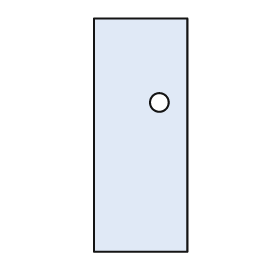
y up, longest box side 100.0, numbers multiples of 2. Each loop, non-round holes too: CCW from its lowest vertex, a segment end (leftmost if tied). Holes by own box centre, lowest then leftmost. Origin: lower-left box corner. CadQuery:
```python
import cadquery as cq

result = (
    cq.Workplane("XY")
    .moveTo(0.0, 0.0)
    .lineTo(40.0, 0.0)
    .lineTo(40.0, 100.0)
    .lineTo(0.0, 100.0)
    .close()
    .moveTo(28.0, 64.0)
    .circle(4.0)
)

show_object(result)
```